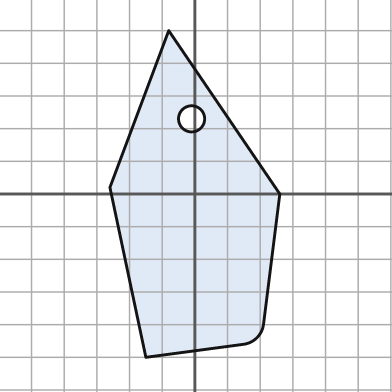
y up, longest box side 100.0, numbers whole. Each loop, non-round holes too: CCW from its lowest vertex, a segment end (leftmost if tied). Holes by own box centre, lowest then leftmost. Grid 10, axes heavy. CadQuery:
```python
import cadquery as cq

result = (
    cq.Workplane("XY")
    .moveTo(-15.0, -50.0)
    .lineTo(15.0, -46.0)
    .threePointArc((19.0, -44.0), (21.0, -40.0))
    .lineTo(26.0, 0.0)
    .lineTo(-8.0, 50.0)
    .lineTo(-26.0, 2.0)
    .close()
    .moveTo(-1.0, 23.0)
    .circle(4.0)
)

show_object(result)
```